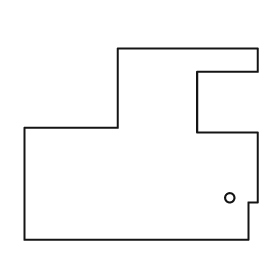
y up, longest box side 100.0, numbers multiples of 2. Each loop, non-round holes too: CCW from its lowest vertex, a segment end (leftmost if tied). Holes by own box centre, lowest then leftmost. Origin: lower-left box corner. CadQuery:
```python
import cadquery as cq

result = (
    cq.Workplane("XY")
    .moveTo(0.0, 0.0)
    .lineTo(96.0, 0.0)
    .lineTo(96.0, 16.0)
    .lineTo(100.0, 16.0)
    .lineTo(100.0, 46.0)
    .lineTo(74.0, 46.0)
    .lineTo(74.0, 72.0)
    .lineTo(100.0, 72.0)
    .lineTo(100.0, 82.0)
    .lineTo(40.0, 82.0)
    .lineTo(40.0, 48.0)
    .lineTo(0.0, 48.0)
    .close()
    .moveTo(88.0, 18.0)
    .circle(2.0)
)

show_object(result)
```